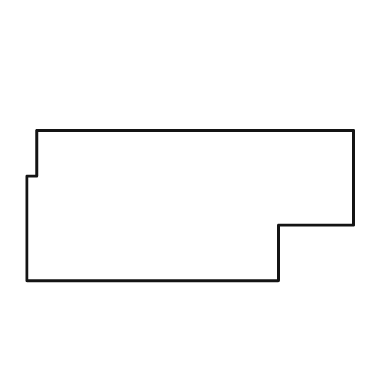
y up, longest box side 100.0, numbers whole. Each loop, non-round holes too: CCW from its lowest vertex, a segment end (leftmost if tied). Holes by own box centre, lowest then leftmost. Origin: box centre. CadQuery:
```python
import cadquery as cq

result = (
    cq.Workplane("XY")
    .moveTo(-50.0, -23.0)
    .lineTo(27.0, -23.0)
    .lineTo(27.0, -6.0)
    .lineTo(50.0, -6.0)
    .lineTo(50.0, 23.0)
    .lineTo(-47.0, 23.0)
    .lineTo(-47.0, 9.0)
    .lineTo(-50.0, 9.0)
    .close()
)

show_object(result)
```